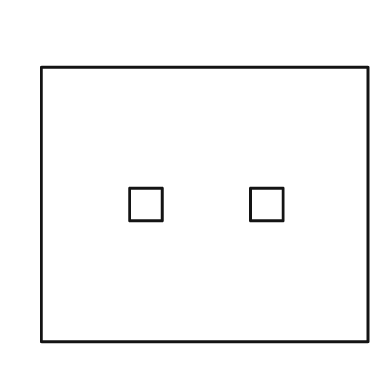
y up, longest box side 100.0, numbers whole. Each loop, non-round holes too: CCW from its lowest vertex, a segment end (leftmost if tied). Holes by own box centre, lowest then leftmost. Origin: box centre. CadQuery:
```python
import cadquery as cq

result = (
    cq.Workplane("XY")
    .moveTo(-50.0, -42.0)
    .lineTo(50.0, -42.0)
    .lineTo(50.0, 42.0)
    .lineTo(-50.0, 42.0)
    .close()
    .moveTo(-23.0, -5.0)
    .lineTo(-13.0, -5.0)
    .lineTo(-13.0, 5.0)
    .lineTo(-23.0, 5.0)
    .close()
    .moveTo(14.0, -5.0)
    .lineTo(24.0, -5.0)
    .lineTo(24.0, 5.0)
    .lineTo(14.0, 5.0)
    .close()
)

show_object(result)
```